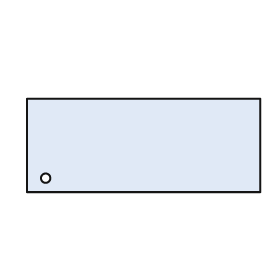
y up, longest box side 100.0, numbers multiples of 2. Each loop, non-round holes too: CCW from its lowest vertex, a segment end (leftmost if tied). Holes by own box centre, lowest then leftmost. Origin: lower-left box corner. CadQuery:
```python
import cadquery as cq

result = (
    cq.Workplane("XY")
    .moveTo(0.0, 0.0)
    .lineTo(100.0, 0.0)
    .lineTo(100.0, 40.0)
    .lineTo(0.0, 40.0)
    .close()
    .moveTo(8.0, 6.0)
    .circle(2.0)
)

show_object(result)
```